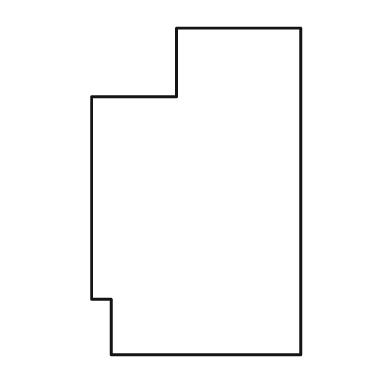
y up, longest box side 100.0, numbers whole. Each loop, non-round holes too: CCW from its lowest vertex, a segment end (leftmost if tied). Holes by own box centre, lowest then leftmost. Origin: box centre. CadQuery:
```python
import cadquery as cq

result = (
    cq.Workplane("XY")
    .moveTo(-26.0, -50.0)
    .lineTo(32.0, -50.0)
    .lineTo(32.0, 50.0)
    .lineTo(-6.0, 50.0)
    .lineTo(-6.0, 29.0)
    .lineTo(-32.0, 29.0)
    .lineTo(-32.0, -33.0)
    .lineTo(-26.0, -33.0)
    .close()
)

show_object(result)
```